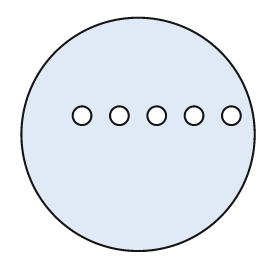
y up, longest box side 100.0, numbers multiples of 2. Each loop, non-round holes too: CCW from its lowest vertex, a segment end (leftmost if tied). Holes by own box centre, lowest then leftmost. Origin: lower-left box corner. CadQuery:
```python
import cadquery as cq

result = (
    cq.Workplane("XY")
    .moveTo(50.0, 50.0)
    .circle(50.0)
    .moveTo(26.0, 58.0)
    .circle(4.0)
    .moveTo(42.0, 58.0)
    .circle(4.0)
    .moveTo(58.0, 58.0)
    .circle(4.0)
    .moveTo(74.0, 58.0)
    .circle(4.0)
    .moveTo(90.0, 58.0)
    .circle(4.0)
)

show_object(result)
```